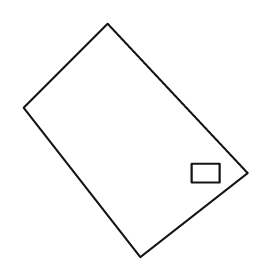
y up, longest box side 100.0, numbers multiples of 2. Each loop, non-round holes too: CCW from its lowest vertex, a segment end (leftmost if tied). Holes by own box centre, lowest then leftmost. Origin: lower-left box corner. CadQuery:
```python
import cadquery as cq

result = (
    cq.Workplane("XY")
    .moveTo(50.0, 0.0)
    .lineTo(96.0, 36.0)
    .lineTo(36.0, 100.0)
    .lineTo(0.0, 64.0)
    .close()
    .moveTo(72.0, 32.0)
    .lineTo(84.0, 32.0)
    .lineTo(84.0, 40.0)
    .lineTo(72.0, 40.0)
    .close()
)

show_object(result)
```